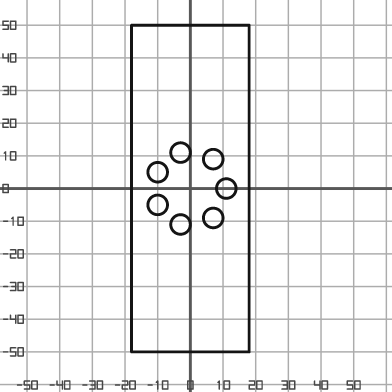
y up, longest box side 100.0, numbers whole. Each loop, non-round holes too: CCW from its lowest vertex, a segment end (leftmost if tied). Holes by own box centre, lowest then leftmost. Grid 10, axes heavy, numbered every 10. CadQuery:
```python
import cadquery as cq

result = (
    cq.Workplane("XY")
    .moveTo(-18.0, -50.0)
    .lineTo(18.0, -50.0)
    .lineTo(18.0, 50.0)
    .lineTo(-18.0, 50.0)
    .close()
    .moveTo(-3.0, -11.0)
    .circle(3.0)
    .moveTo(7.0, -9.0)
    .circle(3.0)
    .moveTo(-10.0, -5.0)
    .circle(3.0)
    .moveTo(11.0, 0.0)
    .circle(3.0)
    .moveTo(-10.0, 5.0)
    .circle(3.0)
    .moveTo(7.0, 9.0)
    .circle(3.0)
    .moveTo(-3.0, 11.0)
    .circle(3.0)
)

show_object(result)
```